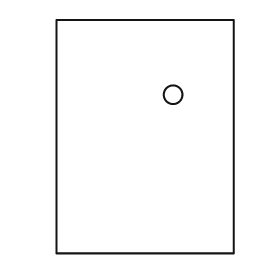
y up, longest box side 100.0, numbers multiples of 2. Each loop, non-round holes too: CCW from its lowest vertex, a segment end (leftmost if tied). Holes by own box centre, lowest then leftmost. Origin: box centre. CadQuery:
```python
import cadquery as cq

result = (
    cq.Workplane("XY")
    .moveTo(-38.0, -50.0)
    .lineTo(38.0, -50.0)
    .lineTo(38.0, 50.0)
    .lineTo(-38.0, 50.0)
    .close()
    .moveTo(12.0, 18.0)
    .circle(4.0)
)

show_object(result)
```